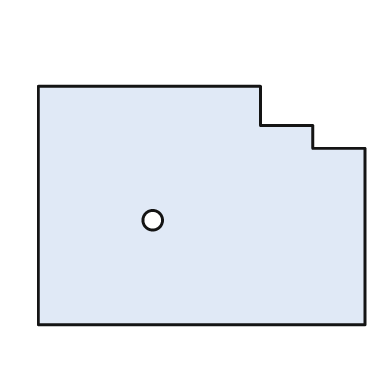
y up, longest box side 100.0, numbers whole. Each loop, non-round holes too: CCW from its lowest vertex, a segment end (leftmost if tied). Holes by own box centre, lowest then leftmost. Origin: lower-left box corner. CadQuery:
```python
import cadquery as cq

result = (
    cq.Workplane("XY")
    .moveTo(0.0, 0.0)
    .lineTo(100.0, 0.0)
    .lineTo(100.0, 54.0)
    .lineTo(84.0, 54.0)
    .lineTo(84.0, 61.0)
    .lineTo(68.0, 61.0)
    .lineTo(68.0, 73.0)
    .lineTo(0.0, 73.0)
    .close()
    .moveTo(35.0, 32.0)
    .circle(3.0)
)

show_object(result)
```